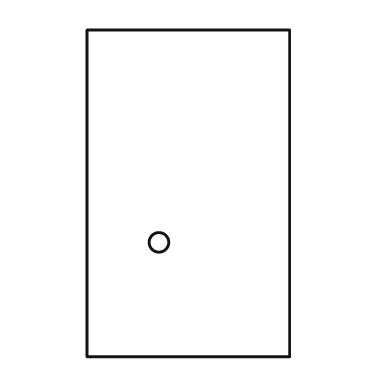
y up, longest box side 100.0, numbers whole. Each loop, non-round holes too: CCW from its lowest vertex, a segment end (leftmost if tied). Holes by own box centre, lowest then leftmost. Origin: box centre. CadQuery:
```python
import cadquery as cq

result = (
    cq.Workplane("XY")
    .moveTo(-31.0, -50.0)
    .lineTo(31.0, -50.0)
    .lineTo(31.0, 50.0)
    .lineTo(-31.0, 50.0)
    .close()
    .moveTo(-9.0, -15.0)
    .circle(3.0)
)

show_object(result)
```